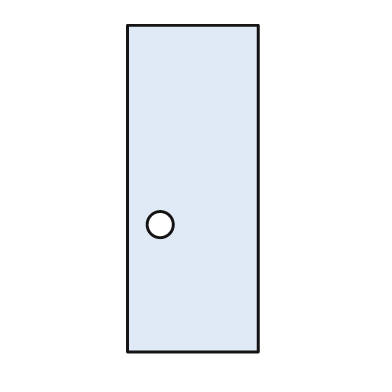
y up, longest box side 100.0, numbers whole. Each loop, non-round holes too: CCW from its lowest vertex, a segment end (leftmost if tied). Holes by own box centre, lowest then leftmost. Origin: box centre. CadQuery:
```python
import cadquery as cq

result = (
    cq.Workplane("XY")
    .moveTo(-20.0, -50.0)
    .lineTo(20.0, -50.0)
    .lineTo(20.0, 50.0)
    .lineTo(-20.0, 50.0)
    .close()
    .moveTo(-10.0, -11.0)
    .circle(4.0)
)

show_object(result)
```